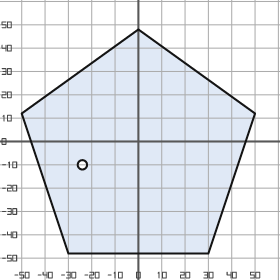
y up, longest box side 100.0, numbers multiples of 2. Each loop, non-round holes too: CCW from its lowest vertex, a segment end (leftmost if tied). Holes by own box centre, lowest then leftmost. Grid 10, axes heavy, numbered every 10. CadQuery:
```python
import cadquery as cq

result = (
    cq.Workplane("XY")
    .moveTo(-30.0, -48.0)
    .lineTo(30.0, -48.0)
    .lineTo(50.0, 12.0)
    .lineTo(0.0, 48.0)
    .lineTo(-50.0, 12.0)
    .close()
    .moveTo(-24.0, -10.0)
    .circle(2.0)
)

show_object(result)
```